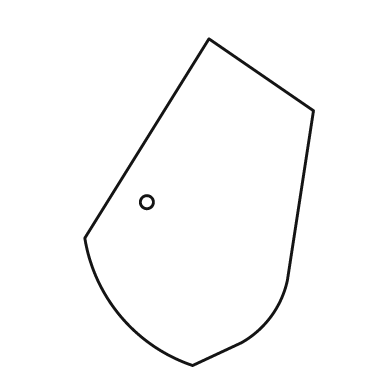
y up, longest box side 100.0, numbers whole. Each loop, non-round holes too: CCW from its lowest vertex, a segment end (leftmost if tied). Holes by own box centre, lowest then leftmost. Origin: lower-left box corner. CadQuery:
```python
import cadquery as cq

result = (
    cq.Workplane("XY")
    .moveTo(33.0, 0.0)
    .lineTo(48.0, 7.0)
    .threePointArc((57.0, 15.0), (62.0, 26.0))
    .lineTo(70.0, 78.0)
    .lineTo(38.0, 100.0)
    .lineTo(0.0, 39.0)
    .threePointArc((11.0, 15.0), (33.0, 0.0))
    .close()
    .moveTo(19.0, 50.0)
    .circle(2.0)
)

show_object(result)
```